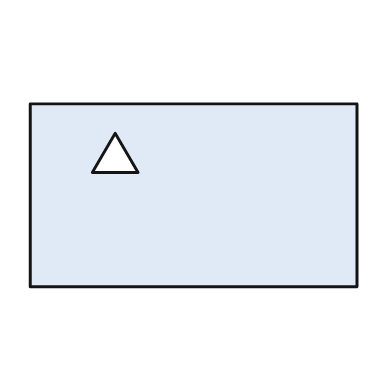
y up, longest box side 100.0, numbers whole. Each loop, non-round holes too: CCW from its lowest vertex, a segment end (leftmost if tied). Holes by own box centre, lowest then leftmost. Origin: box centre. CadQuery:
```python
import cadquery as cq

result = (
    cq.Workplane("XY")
    .moveTo(-50.0, -28.0)
    .lineTo(50.0, -28.0)
    .lineTo(50.0, 28.0)
    .lineTo(-50.0, 28.0)
    .close()
    .moveTo(-31.0, 7.0)
    .lineTo(-17.0, 7.0)
    .lineTo(-24.0, 19.0)
    .close()
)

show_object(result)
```